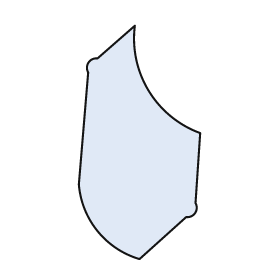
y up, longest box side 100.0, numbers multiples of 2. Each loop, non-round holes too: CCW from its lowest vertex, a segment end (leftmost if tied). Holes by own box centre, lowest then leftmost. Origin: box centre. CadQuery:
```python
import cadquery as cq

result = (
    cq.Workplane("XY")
    .moveTo(0.0, -50.0)
    .lineTo(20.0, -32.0)
    .threePointArc((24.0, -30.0), (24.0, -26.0))
    .lineTo(26.0, 4.0)
    .threePointArc((4.0, 22.0), (-2.0, 50.0))
    .lineTo(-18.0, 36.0)
    .threePointArc((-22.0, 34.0), (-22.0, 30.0))
    .lineTo(-26.0, -18.0)
    .threePointArc((-18.0, -38.0), (0.0, -50.0))
    .close()
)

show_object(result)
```